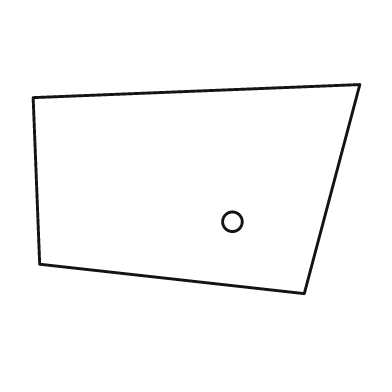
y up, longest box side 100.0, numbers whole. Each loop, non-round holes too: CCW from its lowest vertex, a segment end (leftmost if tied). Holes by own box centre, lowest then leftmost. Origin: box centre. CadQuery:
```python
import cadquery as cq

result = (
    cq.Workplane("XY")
    .moveTo(33.0, -32.0)
    .lineTo(50.0, 32.0)
    .lineTo(-50.0, 28.0)
    .lineTo(-48.0, -23.0)
    .close()
    .moveTo(11.0, -10.0)
    .circle(3.0)
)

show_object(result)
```